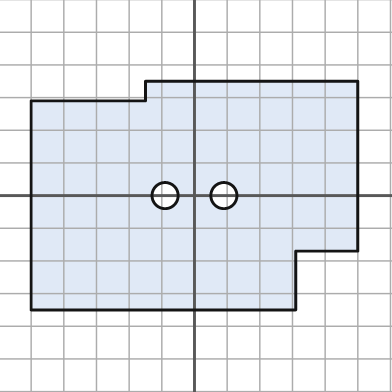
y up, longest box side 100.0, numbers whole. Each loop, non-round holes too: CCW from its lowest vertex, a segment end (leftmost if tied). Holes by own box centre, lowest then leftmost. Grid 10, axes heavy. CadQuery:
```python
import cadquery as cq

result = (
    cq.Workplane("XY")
    .moveTo(-50.0, -35.0)
    .lineTo(31.0, -35.0)
    .lineTo(31.0, -17.0)
    .lineTo(50.0, -17.0)
    .lineTo(50.0, 35.0)
    .lineTo(-15.0, 35.0)
    .lineTo(-15.0, 29.0)
    .lineTo(-50.0, 29.0)
    .close()
    .moveTo(-9.0, 0.0)
    .circle(4.0)
    .moveTo(9.0, 0.0)
    .circle(4.0)
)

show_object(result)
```